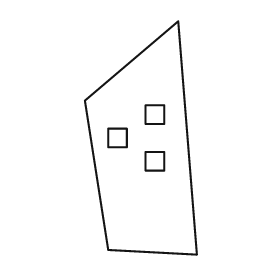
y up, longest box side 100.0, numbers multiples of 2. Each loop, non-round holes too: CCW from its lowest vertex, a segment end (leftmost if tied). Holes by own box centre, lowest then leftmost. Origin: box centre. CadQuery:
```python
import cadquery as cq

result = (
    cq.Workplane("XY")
    .moveTo(24.0, -50.0)
    .lineTo(16.0, 50.0)
    .lineTo(-24.0, 16.0)
    .lineTo(-14.0, -48.0)
    .close()
    .moveTo(2.0, -14.0)
    .lineTo(10.0, -14.0)
    .lineTo(10.0, -6.0)
    .lineTo(2.0, -6.0)
    .close()
    .moveTo(-14.0, -4.0)
    .lineTo(-6.0, -4.0)
    .lineTo(-6.0, 4.0)
    .lineTo(-14.0, 4.0)
    .close()
    .moveTo(2.0, 6.0)
    .lineTo(10.0, 6.0)
    .lineTo(10.0, 14.0)
    .lineTo(2.0, 14.0)
    .close()
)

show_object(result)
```